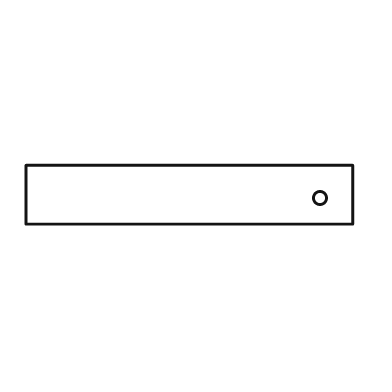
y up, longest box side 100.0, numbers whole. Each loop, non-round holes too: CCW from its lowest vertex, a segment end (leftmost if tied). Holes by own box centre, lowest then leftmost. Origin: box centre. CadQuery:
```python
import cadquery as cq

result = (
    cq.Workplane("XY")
    .moveTo(-50.0, -9.0)
    .lineTo(50.0, -9.0)
    .lineTo(50.0, 9.0)
    .lineTo(-50.0, 9.0)
    .close()
    .moveTo(40.0, -1.0)
    .circle(2.0)
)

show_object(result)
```